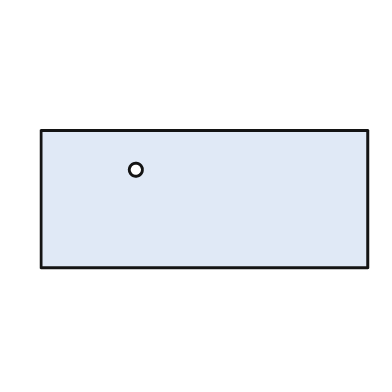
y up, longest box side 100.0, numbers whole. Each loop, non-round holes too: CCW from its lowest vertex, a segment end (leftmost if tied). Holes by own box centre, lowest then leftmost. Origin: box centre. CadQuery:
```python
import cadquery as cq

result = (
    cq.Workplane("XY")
    .moveTo(-50.0, -21.0)
    .lineTo(50.0, -21.0)
    .lineTo(50.0, 21.0)
    .lineTo(-50.0, 21.0)
    .close()
    .moveTo(-21.0, 9.0)
    .circle(2.0)
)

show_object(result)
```